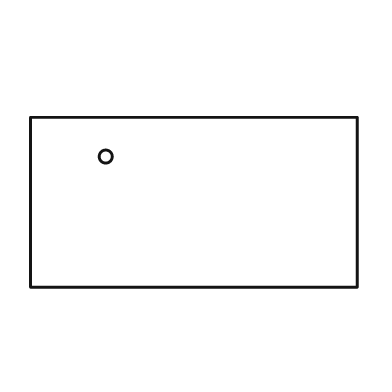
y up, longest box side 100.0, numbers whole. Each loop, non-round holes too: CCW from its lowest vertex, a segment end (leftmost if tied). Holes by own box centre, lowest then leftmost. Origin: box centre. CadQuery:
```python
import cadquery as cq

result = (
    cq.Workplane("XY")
    .moveTo(-50.0, -26.0)
    .lineTo(50.0, -26.0)
    .lineTo(50.0, 26.0)
    .lineTo(-50.0, 26.0)
    .close()
    .moveTo(-27.0, 14.0)
    .circle(2.0)
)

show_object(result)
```